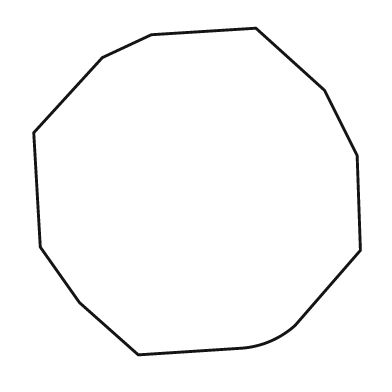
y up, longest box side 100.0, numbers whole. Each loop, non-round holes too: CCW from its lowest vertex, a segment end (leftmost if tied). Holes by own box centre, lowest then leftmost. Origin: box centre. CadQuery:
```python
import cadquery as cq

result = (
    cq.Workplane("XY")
    .moveTo(-18.0, -50.0)
    .lineTo(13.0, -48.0)
    .threePointArc((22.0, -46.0), (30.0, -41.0))
    .lineTo(50.0, -18.0)
    .lineTo(49.0, 11.0)
    .lineTo(39.0, 31.0)
    .lineTo(18.0, 50.0)
    .lineTo(-14.0, 48.0)
    .lineTo(-29.0, 41.0)
    .lineTo(-50.0, 18.0)
    .lineTo(-48.0, -17.0)
    .lineTo(-36.0, -34.0)
    .close()
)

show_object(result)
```